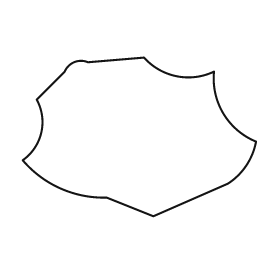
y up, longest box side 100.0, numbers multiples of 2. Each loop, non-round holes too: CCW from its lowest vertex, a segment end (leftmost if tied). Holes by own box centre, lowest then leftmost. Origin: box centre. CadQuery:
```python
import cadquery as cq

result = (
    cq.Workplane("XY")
    .moveTo(6.0, -34.0)
    .lineTo(38.0, -20.0)
    .threePointArc((46.0, -12.0), (50.0, -2.0))
    .threePointArc((36.0, 10.0), (32.0, 28.0))
    .threePointArc((16.0, 26.0), (2.0, 34.0))
    .lineTo(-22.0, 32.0)
    .threePointArc((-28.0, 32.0), (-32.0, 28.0))
    .lineTo(-44.0, 16.0)
    .threePointArc((-42.0, 2.0), (-50.0, -10.0))
    .threePointArc((-34.0, -22.0), (-14.0, -26.0))
    .close()
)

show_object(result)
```